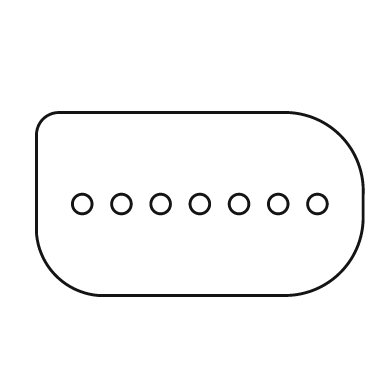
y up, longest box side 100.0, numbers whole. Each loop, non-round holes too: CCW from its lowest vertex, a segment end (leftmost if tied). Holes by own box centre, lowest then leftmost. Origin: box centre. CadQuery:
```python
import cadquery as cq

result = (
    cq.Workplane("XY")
    .moveTo(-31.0, -28.0)
    .lineTo(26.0, -28.0)
    .threePointArc((43.0, -21.0), (50.0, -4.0))
    .lineTo(50.0, 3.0)
    .threePointArc((43.0, 21.0), (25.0, 28.0))
    .lineTo(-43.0, 28.0)
    .threePointArc((-48.0, 26.0), (-50.0, 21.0))
    .lineTo(-50.0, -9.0)
    .threePointArc((-44.0, -22.0), (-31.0, -28.0))
    .close()
    .moveTo(-36.0, 0.0)
    .circle(3.0)
    .moveTo(-24.0, 0.0)
    .circle(3.0)
    .moveTo(-12.0, 0.0)
    .circle(3.0)
    .moveTo(0.0, 0.0)
    .circle(3.0)
    .moveTo(12.0, 0.0)
    .circle(3.0)
    .moveTo(24.0, 0.0)
    .circle(3.0)
    .moveTo(36.0, 0.0)
    .circle(3.0)
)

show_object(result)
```